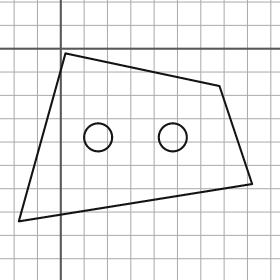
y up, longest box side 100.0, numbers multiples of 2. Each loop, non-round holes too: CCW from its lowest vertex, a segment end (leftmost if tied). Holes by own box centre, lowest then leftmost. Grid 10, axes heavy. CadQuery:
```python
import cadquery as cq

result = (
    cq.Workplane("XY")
    .moveTo(-18.0, -74.0)
    .lineTo(82.0, -58.0)
    .lineTo(68.0, -16.0)
    .lineTo(2.0, -2.0)
    .close()
    .moveTo(16.0, -38.0)
    .circle(6.0)
    .moveTo(48.0, -38.0)
    .circle(6.0)
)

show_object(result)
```